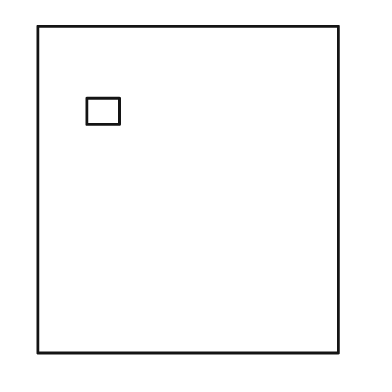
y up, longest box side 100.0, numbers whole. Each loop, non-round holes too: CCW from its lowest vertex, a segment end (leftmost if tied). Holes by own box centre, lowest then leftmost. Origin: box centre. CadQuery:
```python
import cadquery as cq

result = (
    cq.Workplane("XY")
    .moveTo(-46.0, -50.0)
    .lineTo(46.0, -50.0)
    .lineTo(46.0, 50.0)
    .lineTo(-46.0, 50.0)
    .close()
    .moveTo(-31.0, 20.0)
    .lineTo(-21.0, 20.0)
    .lineTo(-21.0, 28.0)
    .lineTo(-31.0, 28.0)
    .close()
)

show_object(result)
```